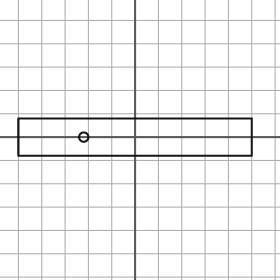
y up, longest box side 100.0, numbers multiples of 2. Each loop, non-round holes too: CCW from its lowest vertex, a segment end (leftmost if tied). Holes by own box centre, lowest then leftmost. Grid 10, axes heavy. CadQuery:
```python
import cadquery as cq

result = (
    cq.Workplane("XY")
    .moveTo(-50.0, -8.0)
    .lineTo(50.0, -8.0)
    .lineTo(50.0, 8.0)
    .lineTo(-50.0, 8.0)
    .close()
    .moveTo(-22.0, 0.0)
    .circle(2.0)
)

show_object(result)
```